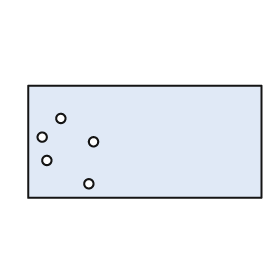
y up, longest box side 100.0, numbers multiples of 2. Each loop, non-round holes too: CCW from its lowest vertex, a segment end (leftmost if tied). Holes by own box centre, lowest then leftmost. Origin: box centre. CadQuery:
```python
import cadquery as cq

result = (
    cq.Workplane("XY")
    .moveTo(-50.0, -24.0)
    .lineTo(50.0, -24.0)
    .lineTo(50.0, 24.0)
    .lineTo(-50.0, 24.0)
    .close()
    .moveTo(-24.0, -18.0)
    .circle(2.0)
    .moveTo(-42.0, -8.0)
    .circle(2.0)
    .moveTo(-22.0, 0.0)
    .circle(2.0)
    .moveTo(-44.0, 2.0)
    .circle(2.0)
    .moveTo(-36.0, 10.0)
    .circle(2.0)
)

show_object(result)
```